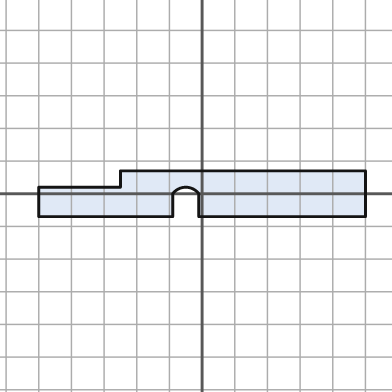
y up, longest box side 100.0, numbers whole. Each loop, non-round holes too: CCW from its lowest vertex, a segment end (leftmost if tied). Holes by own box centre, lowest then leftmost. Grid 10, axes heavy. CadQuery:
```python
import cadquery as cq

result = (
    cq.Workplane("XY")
    .moveTo(-50.0, -7.0)
    .lineTo(-9.0, -7.0)
    .lineTo(-9.0, 0.0)
    .threePointArc((-5.0, 2.0), (-1.0, 0.0))
    .lineTo(-1.0, -7.0)
    .lineTo(50.0, -7.0)
    .lineTo(50.0, 7.0)
    .lineTo(-25.0, 7.0)
    .lineTo(-25.0, 2.0)
    .lineTo(-50.0, 2.0)
    .close()
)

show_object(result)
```